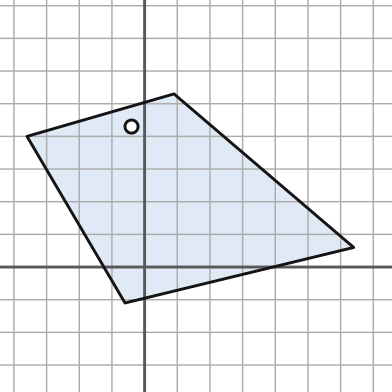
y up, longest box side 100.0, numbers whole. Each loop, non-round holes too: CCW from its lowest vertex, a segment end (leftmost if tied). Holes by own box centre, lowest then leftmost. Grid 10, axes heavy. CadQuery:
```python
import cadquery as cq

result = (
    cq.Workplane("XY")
    .moveTo(-6.0, -11.0)
    .lineTo(64.0, 6.0)
    .lineTo(9.0, 53.0)
    .lineTo(-36.0, 40.0)
    .close()
    .moveTo(-4.0, 43.0)
    .circle(2.0)
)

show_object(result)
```